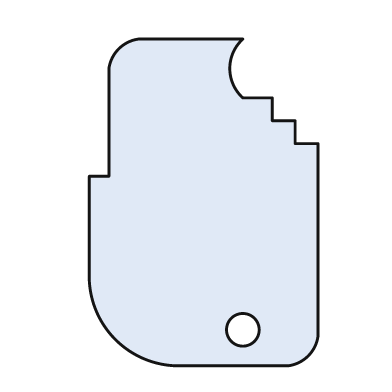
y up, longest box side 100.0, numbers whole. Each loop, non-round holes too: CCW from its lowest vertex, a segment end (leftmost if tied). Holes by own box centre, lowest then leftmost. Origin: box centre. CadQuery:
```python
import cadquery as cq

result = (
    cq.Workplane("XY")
    .moveTo(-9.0, -50.0)
    .lineTo(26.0, -50.0)
    .threePointArc((32.0, -47.0), (35.0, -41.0))
    .lineTo(35.0, 18.0)
    .lineTo(28.0, 18.0)
    .lineTo(28.0, 25.0)
    .lineTo(21.0, 25.0)
    .lineTo(21.0, 32.0)
    .lineTo(12.0, 32.0)
    .threePointArc((8.0, 41.0), (12.0, 50.0))
    .lineTo(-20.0, 50.0)
    .threePointArc((-26.0, 47.0), (-29.0, 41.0))
    .lineTo(-29.0, 8.0)
    .lineTo(-35.0, 8.0)
    .lineTo(-35.0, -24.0)
    .threePointArc((-27.0, -42.0), (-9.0, -50.0))
    .close()
    .moveTo(12.0, -39.0)
    .circle(5.0)
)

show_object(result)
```